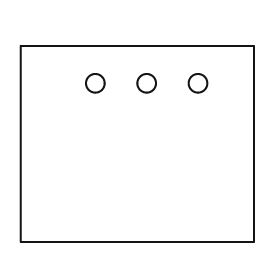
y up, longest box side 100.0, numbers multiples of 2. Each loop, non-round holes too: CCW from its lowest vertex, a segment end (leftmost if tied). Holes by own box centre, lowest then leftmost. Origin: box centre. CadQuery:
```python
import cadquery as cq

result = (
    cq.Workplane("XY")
    .moveTo(-50.0, -42.0)
    .lineTo(50.0, -42.0)
    .lineTo(50.0, 42.0)
    .lineTo(-50.0, 42.0)
    .close()
    .moveTo(-18.0, 26.0)
    .circle(4.0)
    .moveTo(4.0, 26.0)
    .circle(4.0)
    .moveTo(26.0, 26.0)
    .circle(4.0)
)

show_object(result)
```